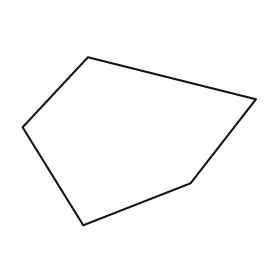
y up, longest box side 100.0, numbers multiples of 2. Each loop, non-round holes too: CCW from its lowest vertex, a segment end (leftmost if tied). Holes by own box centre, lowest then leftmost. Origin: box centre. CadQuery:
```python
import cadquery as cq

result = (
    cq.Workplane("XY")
    .moveTo(-24.0, -36.0)
    .lineTo(22.0, -18.0)
    .lineTo(50.0, 18.0)
    .lineTo(-22.0, 36.0)
    .lineTo(-50.0, 6.0)
    .close()
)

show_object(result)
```